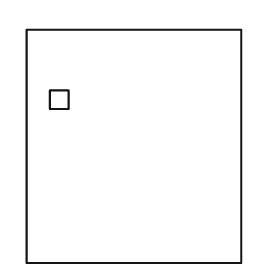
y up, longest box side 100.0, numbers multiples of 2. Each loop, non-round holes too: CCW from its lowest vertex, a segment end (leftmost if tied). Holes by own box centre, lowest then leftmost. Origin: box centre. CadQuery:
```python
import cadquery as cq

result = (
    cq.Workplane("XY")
    .moveTo(-46.0, -50.0)
    .lineTo(46.0, -50.0)
    .lineTo(46.0, 50.0)
    .lineTo(-46.0, 50.0)
    .close()
    .moveTo(-36.0, 16.0)
    .lineTo(-28.0, 16.0)
    .lineTo(-28.0, 24.0)
    .lineTo(-36.0, 24.0)
    .close()
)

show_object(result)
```